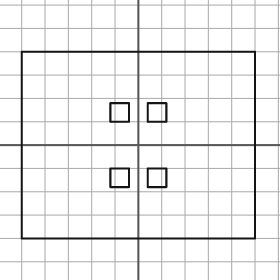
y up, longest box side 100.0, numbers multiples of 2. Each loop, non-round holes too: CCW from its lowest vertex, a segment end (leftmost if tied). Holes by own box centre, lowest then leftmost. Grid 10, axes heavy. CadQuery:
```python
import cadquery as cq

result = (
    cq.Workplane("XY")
    .moveTo(-50.0, -40.0)
    .lineTo(50.0, -40.0)
    .lineTo(50.0, 40.0)
    .lineTo(-50.0, 40.0)
    .close()
    .moveTo(-12.0, -18.0)
    .lineTo(-4.0, -18.0)
    .lineTo(-4.0, -10.0)
    .lineTo(-12.0, -10.0)
    .close()
    .moveTo(4.0, -18.0)
    .lineTo(12.0, -18.0)
    .lineTo(12.0, -10.0)
    .lineTo(4.0, -10.0)
    .close()
    .moveTo(-12.0, 10.0)
    .lineTo(-4.0, 10.0)
    .lineTo(-4.0, 18.0)
    .lineTo(-12.0, 18.0)
    .close()
    .moveTo(4.0, 10.0)
    .lineTo(12.0, 10.0)
    .lineTo(12.0, 18.0)
    .lineTo(4.0, 18.0)
    .close()
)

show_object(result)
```